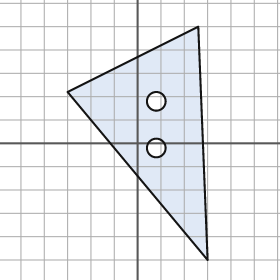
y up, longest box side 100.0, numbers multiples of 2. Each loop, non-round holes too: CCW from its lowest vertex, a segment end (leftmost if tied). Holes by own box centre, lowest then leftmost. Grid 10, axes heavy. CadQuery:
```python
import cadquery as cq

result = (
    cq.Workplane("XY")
    .moveTo(30.0, -50.0)
    .lineTo(26.0, 50.0)
    .lineTo(-30.0, 22.0)
    .close()
    .moveTo(8.0, -2.0)
    .circle(4.0)
    .moveTo(8.0, 18.0)
    .circle(4.0)
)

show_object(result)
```